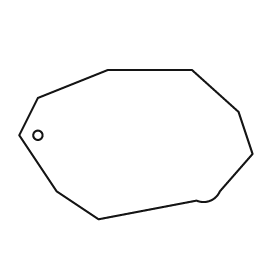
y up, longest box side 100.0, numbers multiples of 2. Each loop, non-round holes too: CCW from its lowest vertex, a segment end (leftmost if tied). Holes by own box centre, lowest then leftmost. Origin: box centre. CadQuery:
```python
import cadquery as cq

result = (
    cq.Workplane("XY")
    .moveTo(-16.0, -32.0)
    .lineTo(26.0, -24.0)
    .threePointArc((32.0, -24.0), (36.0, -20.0))
    .lineTo(50.0, -4.0)
    .lineTo(44.0, 14.0)
    .lineTo(24.0, 32.0)
    .lineTo(-12.0, 32.0)
    .lineTo(-42.0, 20.0)
    .lineTo(-50.0, 4.0)
    .lineTo(-34.0, -20.0)
    .close()
    .moveTo(-42.0, 4.0)
    .circle(2.0)
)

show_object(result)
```